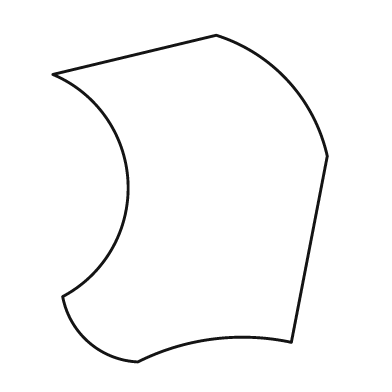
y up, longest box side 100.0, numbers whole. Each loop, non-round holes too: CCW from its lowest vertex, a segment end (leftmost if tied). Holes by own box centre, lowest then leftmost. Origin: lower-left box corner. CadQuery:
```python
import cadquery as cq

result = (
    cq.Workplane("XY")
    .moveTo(26.0, 0.0)
    .threePointArc((49.0, 7.0), (73.0, 6.0))
    .lineTo(84.0, 63.0)
    .threePointArc((72.0, 86.0), (50.0, 100.0))
    .lineTo(0.0, 88.0)
    .threePointArc((23.0, 55.0), (3.0, 20.0))
    .threePointArc((11.0, 6.0), (26.0, 0.0))
    .close()
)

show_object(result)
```